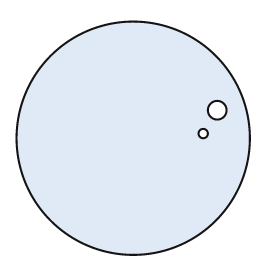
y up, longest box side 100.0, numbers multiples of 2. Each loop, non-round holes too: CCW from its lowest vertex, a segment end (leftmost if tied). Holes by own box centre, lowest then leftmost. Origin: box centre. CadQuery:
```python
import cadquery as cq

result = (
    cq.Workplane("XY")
    .moveTo(0.0, 0.0)
    .circle(50.0)
    .moveTo(30.0, 2.0)
    .circle(2.0)
    .moveTo(36.0, 12.0)
    .circle(4.0)
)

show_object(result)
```